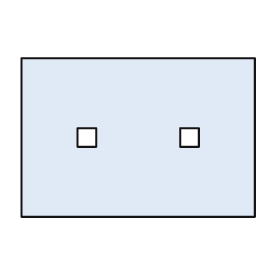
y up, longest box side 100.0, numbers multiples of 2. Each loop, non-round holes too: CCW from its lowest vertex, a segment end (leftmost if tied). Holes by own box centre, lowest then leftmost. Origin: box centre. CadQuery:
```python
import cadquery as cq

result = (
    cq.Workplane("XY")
    .moveTo(-50.0, -34.0)
    .lineTo(50.0, -34.0)
    .lineTo(50.0, 34.0)
    .lineTo(-50.0, 34.0)
    .close()
    .moveTo(-26.0, -4.0)
    .lineTo(-18.0, -4.0)
    .lineTo(-18.0, 4.0)
    .lineTo(-26.0, 4.0)
    .close()
    .moveTo(18.0, -4.0)
    .lineTo(26.0, -4.0)
    .lineTo(26.0, 4.0)
    .lineTo(18.0, 4.0)
    .close()
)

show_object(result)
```